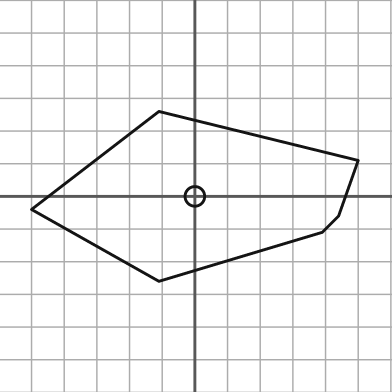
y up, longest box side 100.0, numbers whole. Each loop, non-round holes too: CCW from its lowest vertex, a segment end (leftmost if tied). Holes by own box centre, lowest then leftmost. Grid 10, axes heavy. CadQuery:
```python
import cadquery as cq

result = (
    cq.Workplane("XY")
    .moveTo(-11.0, -26.0)
    .lineTo(39.0, -11.0)
    .lineTo(44.0, -6.0)
    .lineTo(50.0, 11.0)
    .lineTo(-11.0, 26.0)
    .lineTo(-50.0, -4.0)
    .close()
    .moveTo(0.0, 0.0)
    .circle(3.0)
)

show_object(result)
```